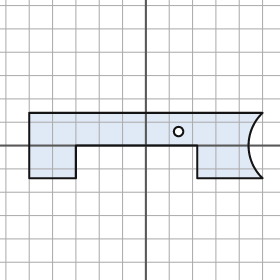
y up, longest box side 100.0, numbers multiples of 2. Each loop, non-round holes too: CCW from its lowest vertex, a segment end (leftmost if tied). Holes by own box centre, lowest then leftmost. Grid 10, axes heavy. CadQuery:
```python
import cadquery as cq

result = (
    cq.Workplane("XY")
    .moveTo(-50.0, -14.0)
    .lineTo(-30.0, -14.0)
    .lineTo(-30.0, 0.0)
    .lineTo(22.0, 0.0)
    .lineTo(22.0, -14.0)
    .lineTo(50.0, -14.0)
    .threePointArc((44.0, 0.0), (50.0, 14.0))
    .lineTo(-50.0, 14.0)
    .close()
    .moveTo(14.0, 6.0)
    .circle(2.0)
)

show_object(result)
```